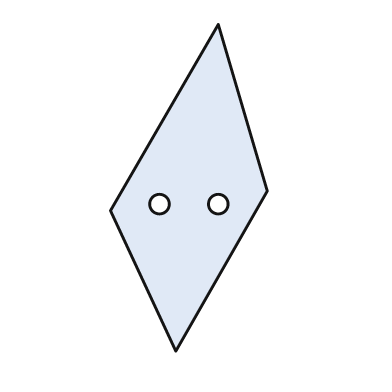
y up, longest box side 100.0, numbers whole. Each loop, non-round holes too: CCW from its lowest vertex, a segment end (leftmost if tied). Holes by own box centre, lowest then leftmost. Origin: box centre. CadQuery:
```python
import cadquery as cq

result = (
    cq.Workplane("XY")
    .moveTo(-4.0, -50.0)
    .lineTo(24.0, -1.0)
    .lineTo(9.0, 50.0)
    .lineTo(-24.0, -7.0)
    .close()
    .moveTo(-9.0, -5.0)
    .circle(3.0)
    .moveTo(9.0, -5.0)
    .circle(3.0)
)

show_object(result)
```